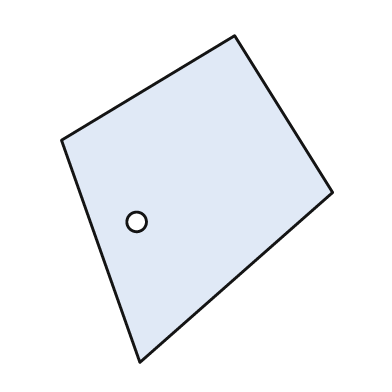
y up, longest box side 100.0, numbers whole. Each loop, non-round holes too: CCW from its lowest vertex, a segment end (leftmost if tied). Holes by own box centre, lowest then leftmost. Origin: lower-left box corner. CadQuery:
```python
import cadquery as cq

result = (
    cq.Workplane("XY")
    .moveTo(24.0, 0.0)
    .lineTo(83.0, 52.0)
    .lineTo(53.0, 100.0)
    .lineTo(0.0, 68.0)
    .close()
    .moveTo(23.0, 43.0)
    .circle(3.0)
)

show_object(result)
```